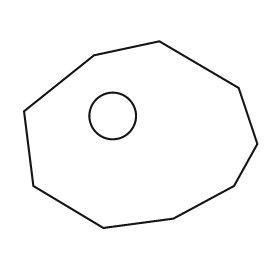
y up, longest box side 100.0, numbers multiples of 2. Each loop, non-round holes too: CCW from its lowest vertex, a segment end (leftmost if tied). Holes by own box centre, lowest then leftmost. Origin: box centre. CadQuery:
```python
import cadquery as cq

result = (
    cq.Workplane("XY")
    .moveTo(-16.0, -40.0)
    .lineTo(14.0, -36.0)
    .lineTo(40.0, -22.0)
    .lineTo(50.0, -4.0)
    .lineTo(42.0, 20.0)
    .lineTo(8.0, 40.0)
    .lineTo(-20.0, 34.0)
    .lineTo(-50.0, 10.0)
    .lineTo(-46.0, -22.0)
    .close()
    .moveTo(-12.0, 8.0)
    .circle(10.0)
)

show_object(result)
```